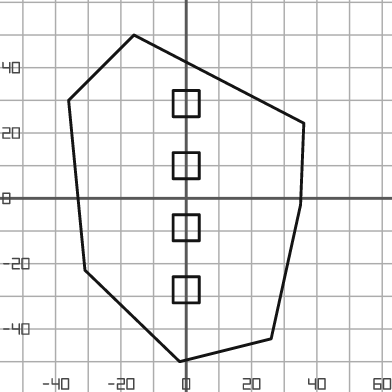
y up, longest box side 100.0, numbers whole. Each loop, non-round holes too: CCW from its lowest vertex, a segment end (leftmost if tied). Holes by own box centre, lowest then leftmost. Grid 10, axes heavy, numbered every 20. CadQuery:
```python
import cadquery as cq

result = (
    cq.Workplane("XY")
    .moveTo(-2.0, -50.0)
    .lineTo(26.0, -43.0)
    .lineTo(35.0, -2.0)
    .lineTo(36.0, 23.0)
    .lineTo(-16.0, 50.0)
    .lineTo(-36.0, 30.0)
    .lineTo(-31.0, -22.0)
    .close()
    .moveTo(-4.0, -32.0)
    .lineTo(4.0, -32.0)
    .lineTo(4.0, -24.0)
    .lineTo(-4.0, -24.0)
    .close()
    .moveTo(-4.0, -13.0)
    .lineTo(4.0, -13.0)
    .lineTo(4.0, -5.0)
    .lineTo(-4.0, -5.0)
    .close()
    .moveTo(-4.0, 6.0)
    .lineTo(4.0, 6.0)
    .lineTo(4.0, 14.0)
    .lineTo(-4.0, 14.0)
    .close()
    .moveTo(-4.0, 25.0)
    .lineTo(4.0, 25.0)
    .lineTo(4.0, 33.0)
    .lineTo(-4.0, 33.0)
    .close()
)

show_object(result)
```